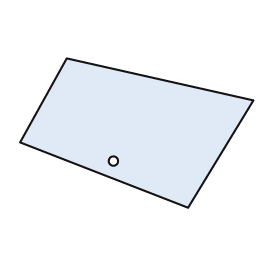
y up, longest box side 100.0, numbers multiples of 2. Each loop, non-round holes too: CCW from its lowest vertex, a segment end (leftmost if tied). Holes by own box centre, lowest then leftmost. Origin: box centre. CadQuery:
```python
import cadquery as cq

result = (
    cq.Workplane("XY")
    .moveTo(22.0, -32.0)
    .lineTo(50.0, 14.0)
    .lineTo(-30.0, 32.0)
    .lineTo(-50.0, -4.0)
    .close()
    .moveTo(-10.0, -12.0)
    .circle(2.0)
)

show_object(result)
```